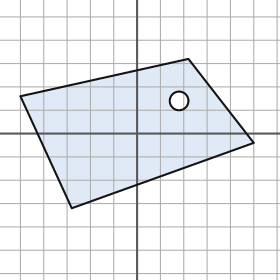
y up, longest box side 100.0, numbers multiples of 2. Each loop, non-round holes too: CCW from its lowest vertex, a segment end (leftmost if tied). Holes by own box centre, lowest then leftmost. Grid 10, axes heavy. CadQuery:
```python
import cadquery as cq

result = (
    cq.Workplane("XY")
    .moveTo(-28.0, -32.0)
    .lineTo(50.0, -4.0)
    .lineTo(22.0, 32.0)
    .lineTo(-50.0, 16.0)
    .close()
    .moveTo(18.0, 14.0)
    .circle(4.0)
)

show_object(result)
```